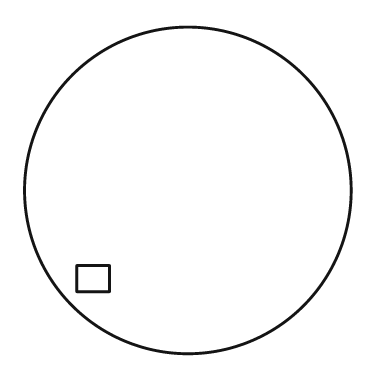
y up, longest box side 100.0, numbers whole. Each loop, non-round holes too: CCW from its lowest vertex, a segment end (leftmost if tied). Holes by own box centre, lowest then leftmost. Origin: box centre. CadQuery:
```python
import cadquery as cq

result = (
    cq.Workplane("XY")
    .moveTo(0.0, 0.0)
    .circle(50.0)
    .moveTo(-34.0, -31.0)
    .lineTo(-24.0, -31.0)
    .lineTo(-24.0, -23.0)
    .lineTo(-34.0, -23.0)
    .close()
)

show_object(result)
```